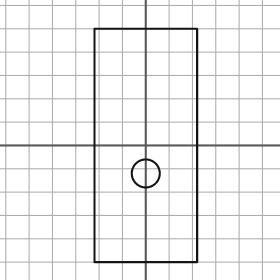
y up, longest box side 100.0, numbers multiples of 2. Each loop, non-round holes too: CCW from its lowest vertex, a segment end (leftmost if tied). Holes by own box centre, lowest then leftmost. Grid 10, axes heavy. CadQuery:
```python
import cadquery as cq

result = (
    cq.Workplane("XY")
    .moveTo(-22.0, -50.0)
    .lineTo(22.0, -50.0)
    .lineTo(22.0, 50.0)
    .lineTo(-22.0, 50.0)
    .close()
    .moveTo(0.0, -12.0)
    .circle(6.0)
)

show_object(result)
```